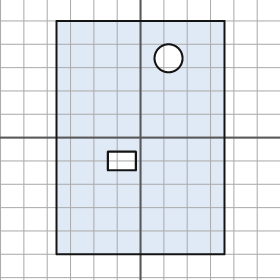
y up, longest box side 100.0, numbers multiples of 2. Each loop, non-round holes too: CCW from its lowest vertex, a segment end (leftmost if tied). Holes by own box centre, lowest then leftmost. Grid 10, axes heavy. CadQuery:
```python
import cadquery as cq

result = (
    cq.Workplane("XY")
    .moveTo(-36.0, -50.0)
    .lineTo(36.0, -50.0)
    .lineTo(36.0, 50.0)
    .lineTo(-36.0, 50.0)
    .close()
    .moveTo(-14.0, -14.0)
    .lineTo(-2.0, -14.0)
    .lineTo(-2.0, -6.0)
    .lineTo(-14.0, -6.0)
    .close()
    .moveTo(12.0, 34.0)
    .circle(6.0)
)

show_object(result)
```